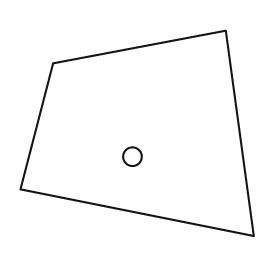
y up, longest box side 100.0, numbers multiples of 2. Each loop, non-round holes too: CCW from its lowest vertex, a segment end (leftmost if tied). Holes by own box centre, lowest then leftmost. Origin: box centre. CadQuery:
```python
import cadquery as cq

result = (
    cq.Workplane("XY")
    .moveTo(50.0, -44.0)
    .lineTo(38.0, 44.0)
    .lineTo(-36.0, 30.0)
    .lineTo(-50.0, -24.0)
    .close()
    .moveTo(-2.0, -10.0)
    .circle(4.0)
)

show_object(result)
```